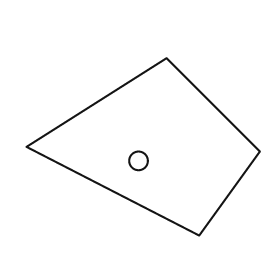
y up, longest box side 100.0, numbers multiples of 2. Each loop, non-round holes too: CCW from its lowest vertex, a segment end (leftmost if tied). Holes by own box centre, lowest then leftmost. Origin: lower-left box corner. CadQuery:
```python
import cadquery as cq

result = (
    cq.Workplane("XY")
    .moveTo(74.0, 0.0)
    .lineTo(100.0, 36.0)
    .lineTo(60.0, 76.0)
    .lineTo(0.0, 38.0)
    .close()
    .moveTo(48.0, 32.0)
    .circle(4.0)
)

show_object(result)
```